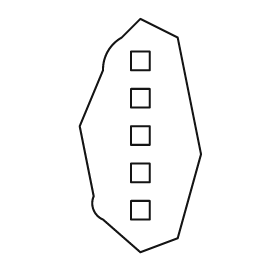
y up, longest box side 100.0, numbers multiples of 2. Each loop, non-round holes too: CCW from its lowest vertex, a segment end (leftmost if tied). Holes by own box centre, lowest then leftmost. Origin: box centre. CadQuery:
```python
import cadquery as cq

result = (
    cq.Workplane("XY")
    .moveTo(0.0, -50.0)
    .lineTo(16.0, -44.0)
    .lineTo(26.0, -8.0)
    .lineTo(16.0, 42.0)
    .lineTo(0.0, 50.0)
    .lineTo(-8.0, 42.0)
    .threePointArc((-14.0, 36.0), (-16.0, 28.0))
    .lineTo(-26.0, 4.0)
    .lineTo(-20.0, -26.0)
    .threePointArc((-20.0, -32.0), (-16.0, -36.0))
    .close()
    .moveTo(-4.0, -36.0)
    .lineTo(4.0, -36.0)
    .lineTo(4.0, -28.0)
    .lineTo(-4.0, -28.0)
    .close()
    .moveTo(-4.0, -20.0)
    .lineTo(4.0, -20.0)
    .lineTo(4.0, -12.0)
    .lineTo(-4.0, -12.0)
    .close()
    .moveTo(-4.0, -4.0)
    .lineTo(4.0, -4.0)
    .lineTo(4.0, 4.0)
    .lineTo(-4.0, 4.0)
    .close()
    .moveTo(-4.0, 12.0)
    .lineTo(4.0, 12.0)
    .lineTo(4.0, 20.0)
    .lineTo(-4.0, 20.0)
    .close()
    .moveTo(-4.0, 28.0)
    .lineTo(4.0, 28.0)
    .lineTo(4.0, 36.0)
    .lineTo(-4.0, 36.0)
    .close()
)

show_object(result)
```